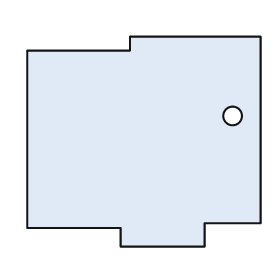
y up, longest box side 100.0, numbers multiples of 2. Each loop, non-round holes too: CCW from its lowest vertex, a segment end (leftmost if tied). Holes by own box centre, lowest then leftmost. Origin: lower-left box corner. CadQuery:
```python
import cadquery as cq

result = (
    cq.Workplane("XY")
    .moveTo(40.0, 0.0)
    .lineTo(76.0, 0.0)
    .lineTo(76.0, 10.0)
    .lineTo(100.0, 10.0)
    .lineTo(100.0, 90.0)
    .lineTo(44.0, 90.0)
    .lineTo(44.0, 84.0)
    .lineTo(0.0, 84.0)
    .lineTo(0.0, 8.0)
    .lineTo(40.0, 8.0)
    .close()
    .moveTo(88.0, 56.0)
    .circle(4.0)
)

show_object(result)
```